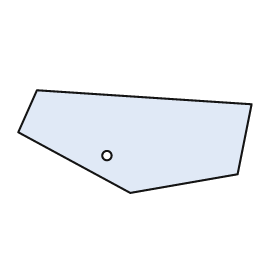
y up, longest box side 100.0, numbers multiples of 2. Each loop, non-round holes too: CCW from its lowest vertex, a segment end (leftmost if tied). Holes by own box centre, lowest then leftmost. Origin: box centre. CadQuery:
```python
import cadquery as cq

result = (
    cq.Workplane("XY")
    .moveTo(-2.0, -22.0)
    .lineTo(44.0, -14.0)
    .lineTo(50.0, 16.0)
    .lineTo(-42.0, 22.0)
    .lineTo(-50.0, 4.0)
    .close()
    .moveTo(-12.0, -6.0)
    .circle(2.0)
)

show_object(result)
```